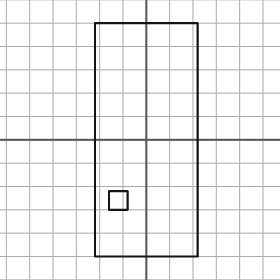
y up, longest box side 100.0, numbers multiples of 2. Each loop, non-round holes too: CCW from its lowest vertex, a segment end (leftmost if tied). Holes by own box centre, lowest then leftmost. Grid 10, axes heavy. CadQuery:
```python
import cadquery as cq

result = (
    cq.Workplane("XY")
    .moveTo(-22.0, -50.0)
    .lineTo(22.0, -50.0)
    .lineTo(22.0, 50.0)
    .lineTo(-22.0, 50.0)
    .close()
    .moveTo(-16.0, -30.0)
    .lineTo(-8.0, -30.0)
    .lineTo(-8.0, -22.0)
    .lineTo(-16.0, -22.0)
    .close()
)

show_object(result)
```